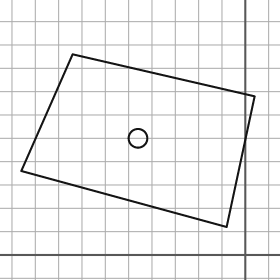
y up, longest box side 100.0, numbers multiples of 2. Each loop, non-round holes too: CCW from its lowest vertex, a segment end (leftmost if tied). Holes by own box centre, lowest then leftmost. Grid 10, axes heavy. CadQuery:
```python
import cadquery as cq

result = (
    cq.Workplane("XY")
    .moveTo(-8.0, 12.0)
    .lineTo(4.0, 68.0)
    .lineTo(-74.0, 86.0)
    .lineTo(-96.0, 36.0)
    .close()
    .moveTo(-46.0, 50.0)
    .circle(4.0)
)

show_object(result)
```